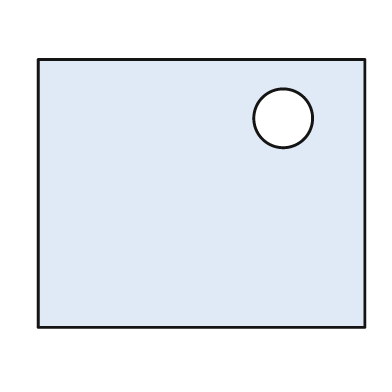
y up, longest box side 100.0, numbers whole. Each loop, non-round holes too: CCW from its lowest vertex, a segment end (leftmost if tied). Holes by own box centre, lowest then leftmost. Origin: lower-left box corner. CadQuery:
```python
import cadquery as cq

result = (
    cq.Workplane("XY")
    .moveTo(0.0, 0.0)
    .lineTo(100.0, 0.0)
    .lineTo(100.0, 82.0)
    .lineTo(0.0, 82.0)
    .close()
    .moveTo(75.0, 64.0)
    .circle(9.0)
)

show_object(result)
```